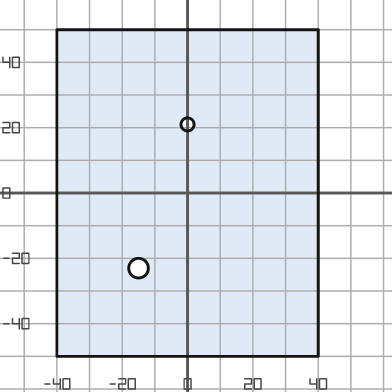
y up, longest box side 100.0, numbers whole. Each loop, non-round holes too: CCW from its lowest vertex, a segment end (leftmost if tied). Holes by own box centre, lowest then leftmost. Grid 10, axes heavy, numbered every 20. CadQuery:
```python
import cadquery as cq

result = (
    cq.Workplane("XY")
    .moveTo(-40.0, -50.0)
    .lineTo(40.0, -50.0)
    .lineTo(40.0, 50.0)
    .lineTo(-40.0, 50.0)
    .close()
    .moveTo(-15.0, -23.0)
    .circle(3.0)
    .moveTo(0.0, 21.0)
    .circle(2.0)
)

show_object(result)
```